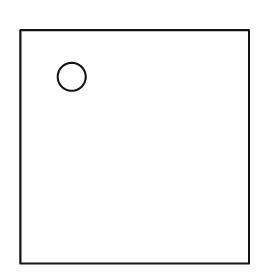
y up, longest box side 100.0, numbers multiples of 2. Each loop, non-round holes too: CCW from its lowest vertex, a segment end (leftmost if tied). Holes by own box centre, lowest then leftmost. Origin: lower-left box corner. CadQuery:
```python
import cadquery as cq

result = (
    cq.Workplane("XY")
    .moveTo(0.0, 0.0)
    .lineTo(98.0, 0.0)
    .lineTo(98.0, 100.0)
    .lineTo(0.0, 100.0)
    .close()
    .moveTo(22.0, 80.0)
    .circle(6.0)
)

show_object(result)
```